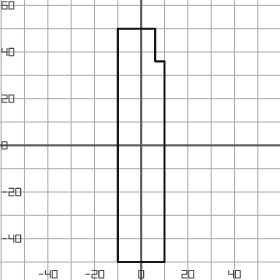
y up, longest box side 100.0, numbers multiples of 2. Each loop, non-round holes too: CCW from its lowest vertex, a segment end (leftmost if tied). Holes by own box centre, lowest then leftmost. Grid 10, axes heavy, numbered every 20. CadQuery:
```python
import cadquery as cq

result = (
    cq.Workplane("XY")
    .moveTo(-10.0, -50.0)
    .lineTo(10.0, -50.0)
    .lineTo(10.0, 36.0)
    .lineTo(6.0, 36.0)
    .lineTo(6.0, 50.0)
    .lineTo(-10.0, 50.0)
    .close()
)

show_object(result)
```